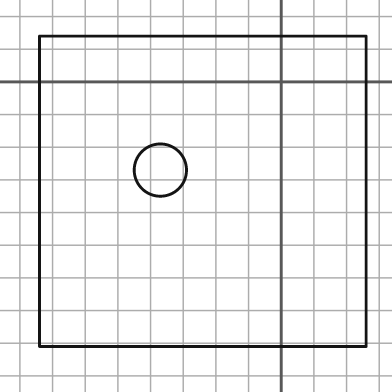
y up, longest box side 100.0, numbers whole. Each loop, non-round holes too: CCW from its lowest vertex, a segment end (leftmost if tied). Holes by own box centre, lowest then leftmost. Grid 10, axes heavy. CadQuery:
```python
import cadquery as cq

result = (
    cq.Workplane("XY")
    .moveTo(-74.0, -81.0)
    .lineTo(26.0, -81.0)
    .lineTo(26.0, 14.0)
    .lineTo(-74.0, 14.0)
    .close()
    .moveTo(-37.0, -27.0)
    .circle(8.0)
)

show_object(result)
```